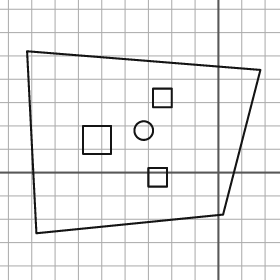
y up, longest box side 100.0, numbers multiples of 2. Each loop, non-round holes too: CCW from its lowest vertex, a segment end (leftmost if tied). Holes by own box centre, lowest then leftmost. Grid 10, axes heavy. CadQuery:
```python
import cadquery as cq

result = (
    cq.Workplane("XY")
    .moveTo(-78.0, -26.0)
    .lineTo(2.0, -18.0)
    .lineTo(18.0, 44.0)
    .lineTo(-82.0, 52.0)
    .close()
    .moveTo(-30.0, -6.0)
    .lineTo(-22.0, -6.0)
    .lineTo(-22.0, 2.0)
    .lineTo(-30.0, 2.0)
    .close()
    .moveTo(-58.0, 8.0)
    .lineTo(-46.0, 8.0)
    .lineTo(-46.0, 20.0)
    .lineTo(-58.0, 20.0)
    .close()
    .moveTo(-32.0, 18.0)
    .circle(4.0)
    .moveTo(-28.0, 28.0)
    .lineTo(-20.0, 28.0)
    .lineTo(-20.0, 36.0)
    .lineTo(-28.0, 36.0)
    .close()
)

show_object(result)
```